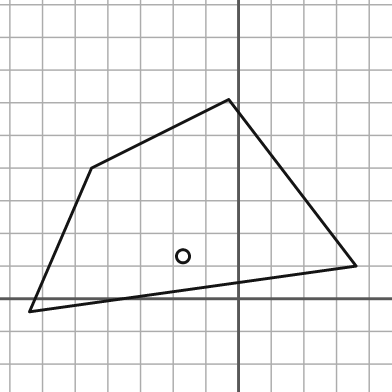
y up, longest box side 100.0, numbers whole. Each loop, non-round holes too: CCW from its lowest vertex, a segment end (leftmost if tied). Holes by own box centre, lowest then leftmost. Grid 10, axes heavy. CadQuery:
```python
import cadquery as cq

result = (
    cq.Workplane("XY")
    .moveTo(-64.0, -4.0)
    .lineTo(36.0, 10.0)
    .lineTo(-3.0, 61.0)
    .lineTo(-45.0, 40.0)
    .close()
    .moveTo(-17.0, 13.0)
    .circle(2.0)
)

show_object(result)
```